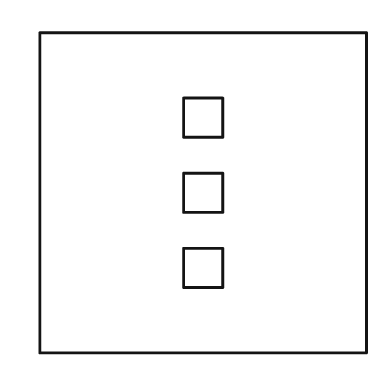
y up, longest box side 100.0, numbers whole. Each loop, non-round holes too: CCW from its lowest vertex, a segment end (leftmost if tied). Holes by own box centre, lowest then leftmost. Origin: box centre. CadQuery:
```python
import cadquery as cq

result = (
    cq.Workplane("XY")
    .moveTo(-50.0, -49.0)
    .lineTo(50.0, -49.0)
    .lineTo(50.0, 49.0)
    .lineTo(-50.0, 49.0)
    .close()
    .moveTo(-6.0, -29.0)
    .lineTo(6.0, -29.0)
    .lineTo(6.0, -17.0)
    .lineTo(-6.0, -17.0)
    .close()
    .moveTo(-6.0, -6.0)
    .lineTo(6.0, -6.0)
    .lineTo(6.0, 6.0)
    .lineTo(-6.0, 6.0)
    .close()
    .moveTo(-6.0, 17.0)
    .lineTo(6.0, 17.0)
    .lineTo(6.0, 29.0)
    .lineTo(-6.0, 29.0)
    .close()
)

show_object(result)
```